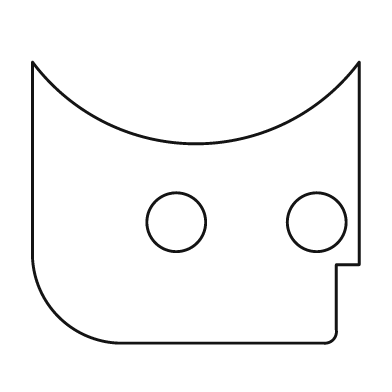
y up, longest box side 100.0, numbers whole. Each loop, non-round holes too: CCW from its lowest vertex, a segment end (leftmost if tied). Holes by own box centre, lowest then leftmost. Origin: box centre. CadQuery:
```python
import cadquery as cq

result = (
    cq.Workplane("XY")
    .moveTo(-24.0, -43.0)
    .lineTo(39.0, -43.0)
    .threePointArc((42.0, -42.0), (43.0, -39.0))
    .lineTo(43.0, -19.0)
    .lineTo(50.0, -19.0)
    .lineTo(50.0, 43.0)
    .threePointArc((0.0, 18.0), (-50.0, 43.0))
    .lineTo(-50.0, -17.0)
    .threePointArc((-42.0, -35.0), (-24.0, -43.0))
    .close()
    .moveTo(-6.0, -6.0)
    .circle(9.0)
    .moveTo(37.0, -6.0)
    .circle(9.0)
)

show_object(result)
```